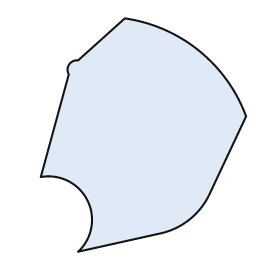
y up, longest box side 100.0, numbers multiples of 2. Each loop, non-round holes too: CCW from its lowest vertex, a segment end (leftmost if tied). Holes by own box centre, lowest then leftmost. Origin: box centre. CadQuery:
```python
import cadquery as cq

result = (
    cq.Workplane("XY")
    .moveTo(-28.0, -50.0)
    .lineTo(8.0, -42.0)
    .threePointArc((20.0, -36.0), (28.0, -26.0))
    .lineTo(44.0, 8.0)
    .threePointArc((24.0, 36.0), (-8.0, 50.0))
    .lineTo(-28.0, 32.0)
    .threePointArc((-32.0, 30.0), (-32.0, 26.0))
    .lineTo(-44.0, -18.0)
    .threePointArc((-24.0, -28.0), (-28.0, -50.0))
    .close()
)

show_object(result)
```